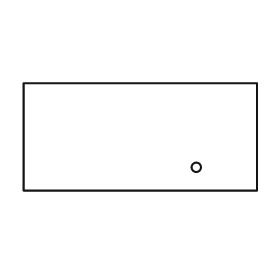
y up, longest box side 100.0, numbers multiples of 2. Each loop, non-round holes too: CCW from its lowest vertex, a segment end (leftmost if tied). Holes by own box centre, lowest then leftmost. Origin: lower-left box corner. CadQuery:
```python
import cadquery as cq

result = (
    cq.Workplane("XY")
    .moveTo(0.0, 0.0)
    .lineTo(100.0, 0.0)
    .lineTo(100.0, 46.0)
    .lineTo(0.0, 46.0)
    .close()
    .moveTo(74.0, 10.0)
    .circle(2.0)
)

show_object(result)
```